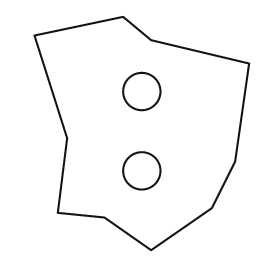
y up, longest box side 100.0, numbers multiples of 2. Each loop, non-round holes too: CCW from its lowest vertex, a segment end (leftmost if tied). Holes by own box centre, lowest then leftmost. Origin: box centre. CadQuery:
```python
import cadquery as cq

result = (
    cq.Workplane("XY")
    .moveTo(4.0, -50.0)
    .lineTo(30.0, -32.0)
    .lineTo(40.0, -12.0)
    .lineTo(46.0, 30.0)
    .lineTo(4.0, 40.0)
    .lineTo(-8.0, 50.0)
    .lineTo(-46.0, 42.0)
    .lineTo(-32.0, -2.0)
    .lineTo(-36.0, -34.0)
    .lineTo(-16.0, -36.0)
    .close()
    .moveTo(0.0, -16.0)
    .circle(8.0)
    .moveTo(0.0, 18.0)
    .circle(8.0)
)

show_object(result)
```